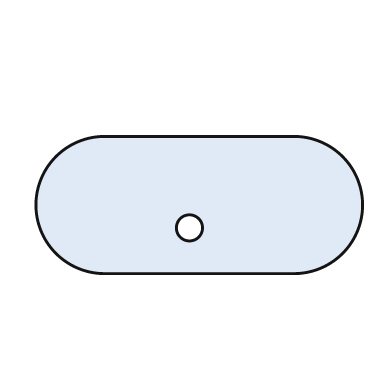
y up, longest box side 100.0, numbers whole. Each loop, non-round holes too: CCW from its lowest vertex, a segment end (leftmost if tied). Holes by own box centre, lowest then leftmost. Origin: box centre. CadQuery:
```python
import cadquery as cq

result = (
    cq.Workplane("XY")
    .moveTo(-29.0, -21.0)
    .lineTo(29.0, -21.0)
    .threePointArc((50.0, 0.0), (29.0, 21.0))
    .lineTo(-29.0, 21.0)
    .threePointArc((-50.0, 0.0), (-29.0, -21.0))
    .close()
    .moveTo(-3.0, -7.0)
    .circle(4.0)
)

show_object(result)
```